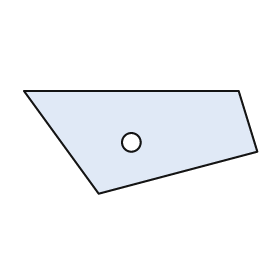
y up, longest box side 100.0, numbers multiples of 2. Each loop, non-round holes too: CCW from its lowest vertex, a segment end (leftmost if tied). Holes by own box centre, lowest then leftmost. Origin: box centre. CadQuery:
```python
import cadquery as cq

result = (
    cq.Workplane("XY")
    .moveTo(-18.0, -22.0)
    .lineTo(50.0, -4.0)
    .lineTo(42.0, 22.0)
    .lineTo(-50.0, 22.0)
    .close()
    .moveTo(-4.0, 0.0)
    .circle(4.0)
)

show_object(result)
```